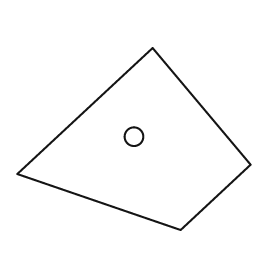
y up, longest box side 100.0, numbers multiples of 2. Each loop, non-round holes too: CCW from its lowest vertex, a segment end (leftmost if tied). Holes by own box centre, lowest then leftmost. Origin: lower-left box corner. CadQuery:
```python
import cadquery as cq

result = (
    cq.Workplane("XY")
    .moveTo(70.0, 0.0)
    .lineTo(100.0, 28.0)
    .lineTo(58.0, 78.0)
    .lineTo(0.0, 24.0)
    .close()
    .moveTo(50.0, 40.0)
    .circle(4.0)
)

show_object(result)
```